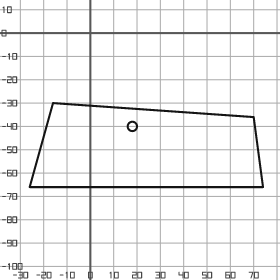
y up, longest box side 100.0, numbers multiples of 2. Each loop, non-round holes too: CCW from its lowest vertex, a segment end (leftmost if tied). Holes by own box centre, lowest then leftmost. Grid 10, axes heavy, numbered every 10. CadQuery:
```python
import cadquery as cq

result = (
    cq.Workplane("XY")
    .moveTo(-26.0, -66.0)
    .lineTo(74.0, -66.0)
    .lineTo(70.0, -36.0)
    .lineTo(-16.0, -30.0)
    .close()
    .moveTo(18.0, -40.0)
    .circle(2.0)
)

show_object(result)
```